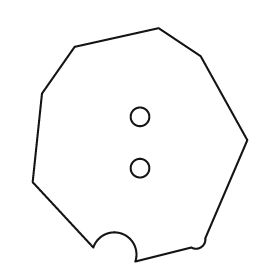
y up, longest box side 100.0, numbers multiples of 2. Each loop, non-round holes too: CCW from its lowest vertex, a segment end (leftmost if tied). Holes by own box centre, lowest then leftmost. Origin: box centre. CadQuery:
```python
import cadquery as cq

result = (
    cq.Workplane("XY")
    .moveTo(-2.0, -50.0)
    .lineTo(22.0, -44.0)
    .threePointArc((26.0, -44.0), (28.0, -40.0))
    .lineTo(46.0, 2.0)
    .lineTo(26.0, 38.0)
    .lineTo(8.0, 50.0)
    .lineTo(-28.0, 42.0)
    .lineTo(-42.0, 22.0)
    .lineTo(-46.0, -16.0)
    .lineTo(-20.0, -44.0)
    .threePointArc((-8.0, -38.0), (-2.0, -50.0))
    .close()
    .moveTo(0.0, -10.0)
    .circle(4.0)
    .moveTo(0.0, 12.0)
    .circle(4.0)
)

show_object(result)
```